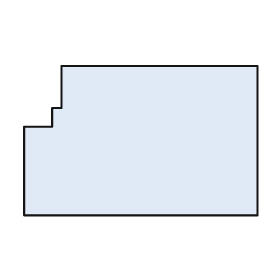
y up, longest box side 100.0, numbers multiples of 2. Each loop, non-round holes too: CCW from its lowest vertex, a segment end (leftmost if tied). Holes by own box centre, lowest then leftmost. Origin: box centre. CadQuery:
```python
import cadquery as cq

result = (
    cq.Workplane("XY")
    .moveTo(-50.0, -32.0)
    .lineTo(50.0, -32.0)
    .lineTo(50.0, 32.0)
    .lineTo(-34.0, 32.0)
    .lineTo(-34.0, 14.0)
    .lineTo(-38.0, 14.0)
    .lineTo(-38.0, 6.0)
    .lineTo(-50.0, 6.0)
    .close()
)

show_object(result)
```